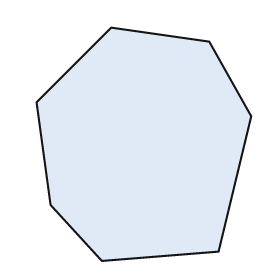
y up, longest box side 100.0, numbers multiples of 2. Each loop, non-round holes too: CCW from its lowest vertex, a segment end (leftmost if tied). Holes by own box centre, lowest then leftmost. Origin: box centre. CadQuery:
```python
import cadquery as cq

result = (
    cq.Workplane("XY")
    .moveTo(-18.0, -50.0)
    .lineTo(32.0, -46.0)
    .lineTo(46.0, 12.0)
    .lineTo(28.0, 44.0)
    .lineTo(-14.0, 50.0)
    .lineTo(-46.0, 18.0)
    .lineTo(-40.0, -26.0)
    .close()
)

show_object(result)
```